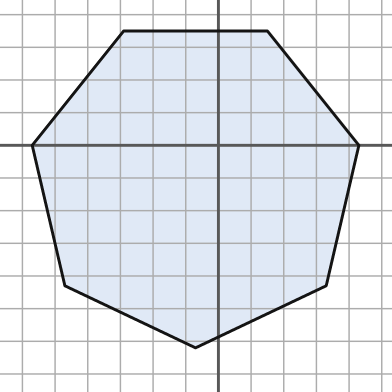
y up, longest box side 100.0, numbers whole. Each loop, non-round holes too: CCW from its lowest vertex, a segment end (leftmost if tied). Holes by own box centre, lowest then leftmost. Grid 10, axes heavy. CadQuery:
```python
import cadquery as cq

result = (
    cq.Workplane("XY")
    .moveTo(-7.0, -62.0)
    .lineTo(33.0, -43.0)
    .lineTo(43.0, 0.0)
    .lineTo(15.0, 35.0)
    .lineTo(-29.0, 35.0)
    .lineTo(-57.0, 0.0)
    .lineTo(-47.0, -43.0)
    .close()
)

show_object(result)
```